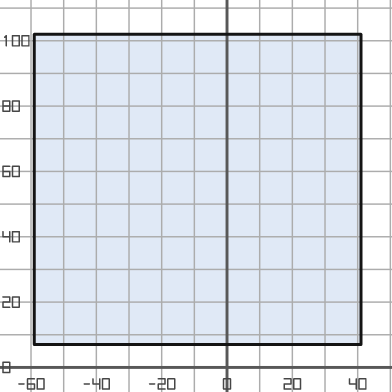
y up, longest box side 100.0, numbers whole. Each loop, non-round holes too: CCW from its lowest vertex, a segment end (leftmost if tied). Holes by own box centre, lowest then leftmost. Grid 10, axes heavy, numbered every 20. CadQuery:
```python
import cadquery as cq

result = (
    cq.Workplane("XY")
    .moveTo(-59.0, 7.0)
    .lineTo(41.0, 7.0)
    .lineTo(41.0, 102.0)
    .lineTo(-59.0, 102.0)
    .close()
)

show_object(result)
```